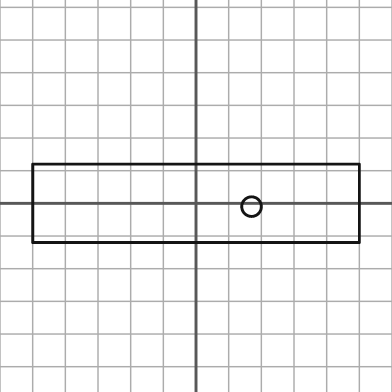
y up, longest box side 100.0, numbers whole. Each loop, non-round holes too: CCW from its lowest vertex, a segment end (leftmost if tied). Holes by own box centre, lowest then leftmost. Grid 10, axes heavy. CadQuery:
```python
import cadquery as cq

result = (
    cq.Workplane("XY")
    .moveTo(-50.0, -12.0)
    .lineTo(50.0, -12.0)
    .lineTo(50.0, 12.0)
    .lineTo(-50.0, 12.0)
    .close()
    .moveTo(17.0, -1.0)
    .circle(3.0)
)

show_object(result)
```